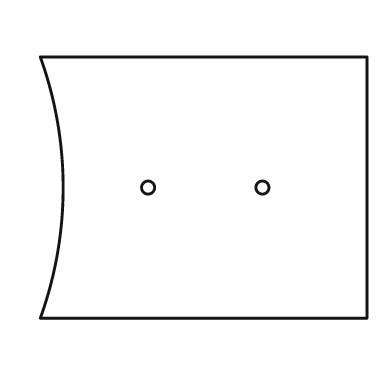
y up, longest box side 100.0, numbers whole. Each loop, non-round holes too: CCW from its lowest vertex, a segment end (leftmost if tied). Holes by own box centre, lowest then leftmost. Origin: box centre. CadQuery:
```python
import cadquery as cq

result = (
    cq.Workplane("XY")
    .moveTo(-50.0, -40.0)
    .lineTo(50.0, -40.0)
    .lineTo(50.0, 40.0)
    .lineTo(-50.0, 40.0)
    .threePointArc((-43.0, 0.0), (-50.0, -40.0))
    .close()
    .moveTo(-17.0, 0.0)
    .circle(2.0)
    .moveTo(18.0, 0.0)
    .circle(2.0)
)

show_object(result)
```